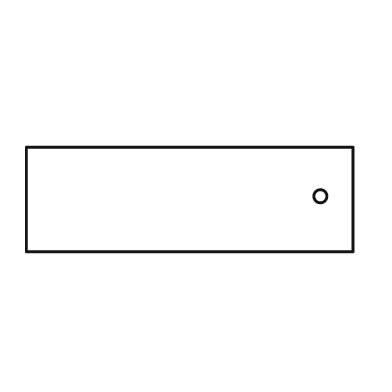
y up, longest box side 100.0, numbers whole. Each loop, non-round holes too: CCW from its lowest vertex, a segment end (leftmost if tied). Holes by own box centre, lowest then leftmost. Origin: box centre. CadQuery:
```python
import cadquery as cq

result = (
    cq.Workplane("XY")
    .moveTo(-50.0, -16.0)
    .lineTo(50.0, -16.0)
    .lineTo(50.0, 16.0)
    .lineTo(-50.0, 16.0)
    .close()
    .moveTo(40.0, 1.0)
    .circle(2.0)
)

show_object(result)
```